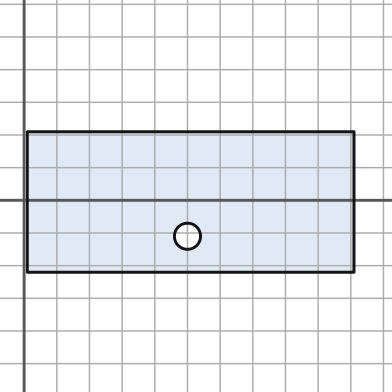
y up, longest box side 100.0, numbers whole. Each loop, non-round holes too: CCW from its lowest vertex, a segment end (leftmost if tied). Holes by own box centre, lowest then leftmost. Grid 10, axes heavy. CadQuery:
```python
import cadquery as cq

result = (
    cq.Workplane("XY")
    .moveTo(1.0, -22.0)
    .lineTo(101.0, -22.0)
    .lineTo(101.0, 21.0)
    .lineTo(1.0, 21.0)
    .close()
    .moveTo(50.0, -11.0)
    .circle(4.0)
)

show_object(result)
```